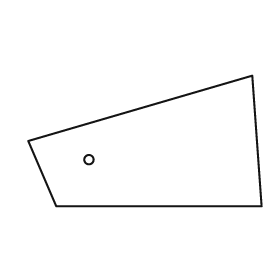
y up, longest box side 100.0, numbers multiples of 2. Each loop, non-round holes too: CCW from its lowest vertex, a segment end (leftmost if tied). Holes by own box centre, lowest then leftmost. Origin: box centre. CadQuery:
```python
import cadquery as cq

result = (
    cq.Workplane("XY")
    .moveTo(-38.0, -28.0)
    .lineTo(50.0, -28.0)
    .lineTo(46.0, 28.0)
    .lineTo(-50.0, 0.0)
    .close()
    .moveTo(-24.0, -8.0)
    .circle(2.0)
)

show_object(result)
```